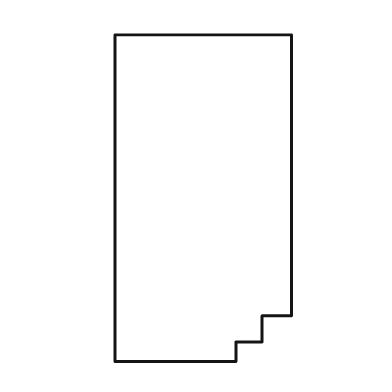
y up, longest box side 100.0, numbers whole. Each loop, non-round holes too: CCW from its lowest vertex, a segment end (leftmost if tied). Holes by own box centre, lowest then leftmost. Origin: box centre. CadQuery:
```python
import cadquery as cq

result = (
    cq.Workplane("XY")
    .moveTo(-27.0, -50.0)
    .lineTo(10.0, -50.0)
    .lineTo(10.0, -44.0)
    .lineTo(18.0, -44.0)
    .lineTo(18.0, -36.0)
    .lineTo(27.0, -36.0)
    .lineTo(27.0, 50.0)
    .lineTo(-27.0, 50.0)
    .close()
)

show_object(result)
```